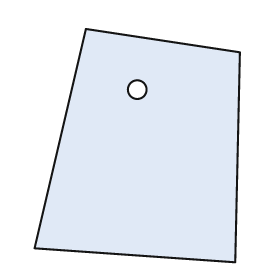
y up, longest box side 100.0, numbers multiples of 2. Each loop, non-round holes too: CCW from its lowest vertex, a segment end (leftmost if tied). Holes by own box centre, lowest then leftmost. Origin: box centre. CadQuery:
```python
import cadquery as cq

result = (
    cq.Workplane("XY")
    .moveTo(42.0, -50.0)
    .lineTo(44.0, 40.0)
    .lineTo(-22.0, 50.0)
    .lineTo(-44.0, -44.0)
    .close()
    .moveTo(0.0, 24.0)
    .circle(4.0)
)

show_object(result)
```